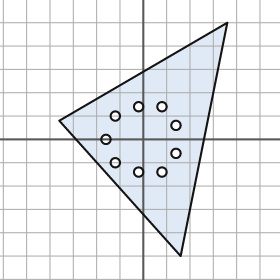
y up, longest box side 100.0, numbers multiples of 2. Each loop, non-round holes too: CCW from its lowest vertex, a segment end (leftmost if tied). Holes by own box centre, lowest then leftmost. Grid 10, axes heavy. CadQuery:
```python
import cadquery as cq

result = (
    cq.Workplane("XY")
    .moveTo(16.0, -50.0)
    .lineTo(36.0, 50.0)
    .lineTo(-36.0, 8.0)
    .close()
    .moveTo(-2.0, -14.0)
    .circle(2.0)
    .moveTo(8.0, -14.0)
    .circle(2.0)
    .moveTo(-12.0, -10.0)
    .circle(2.0)
    .moveTo(14.0, -6.0)
    .circle(2.0)
    .moveTo(-16.0, 0.0)
    .circle(2.0)
    .moveTo(14.0, 6.0)
    .circle(2.0)
    .moveTo(-12.0, 10.0)
    .circle(2.0)
    .moveTo(-2.0, 14.0)
    .circle(2.0)
    .moveTo(8.0, 14.0)
    .circle(2.0)
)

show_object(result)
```